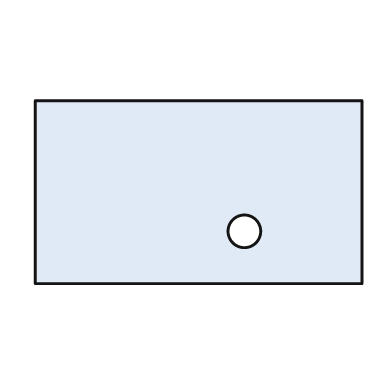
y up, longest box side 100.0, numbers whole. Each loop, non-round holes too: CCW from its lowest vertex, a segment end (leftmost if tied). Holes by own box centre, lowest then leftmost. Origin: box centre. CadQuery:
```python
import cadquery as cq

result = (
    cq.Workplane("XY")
    .moveTo(-50.0, -28.0)
    .lineTo(50.0, -28.0)
    .lineTo(50.0, 28.0)
    .lineTo(-50.0, 28.0)
    .close()
    .moveTo(14.0, -12.0)
    .circle(5.0)
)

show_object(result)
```